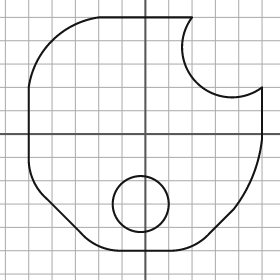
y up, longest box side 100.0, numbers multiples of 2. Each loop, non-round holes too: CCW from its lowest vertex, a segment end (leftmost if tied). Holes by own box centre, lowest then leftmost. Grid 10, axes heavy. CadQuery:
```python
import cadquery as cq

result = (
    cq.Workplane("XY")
    .moveTo(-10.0, -50.0)
    .lineTo(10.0, -50.0)
    .threePointArc((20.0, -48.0), (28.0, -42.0))
    .lineTo(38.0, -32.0)
    .threePointArc((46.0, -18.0), (50.0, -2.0))
    .lineTo(50.0, 20.0)
    .threePointArc((22.0, 22.0), (20.0, 50.0))
    .lineTo(-20.0, 50.0)
    .threePointArc((-40.0, 40.0), (-50.0, 20.0))
    .lineTo(-50.0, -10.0)
    .threePointArc((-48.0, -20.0), (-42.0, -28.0))
    .lineTo(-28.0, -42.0)
    .threePointArc((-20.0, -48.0), (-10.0, -50.0))
    .close()
    .moveTo(-2.0, -30.0)
    .circle(12.0)
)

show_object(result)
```